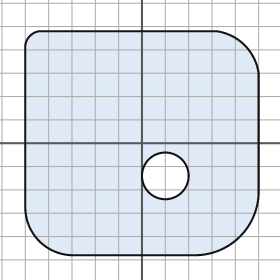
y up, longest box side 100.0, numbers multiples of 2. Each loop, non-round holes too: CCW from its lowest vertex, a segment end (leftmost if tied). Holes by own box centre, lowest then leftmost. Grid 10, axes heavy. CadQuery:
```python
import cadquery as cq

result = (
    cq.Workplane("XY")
    .moveTo(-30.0, -48.0)
    .lineTo(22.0, -48.0)
    .threePointArc((42.0, -40.0), (50.0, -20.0))
    .lineTo(50.0, 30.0)
    .threePointArc((44.0, 42.0), (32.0, 48.0))
    .lineTo(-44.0, 48.0)
    .threePointArc((-48.0, 46.0), (-50.0, 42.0))
    .lineTo(-50.0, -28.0)
    .threePointArc((-44.0, -42.0), (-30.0, -48.0))
    .close()
    .moveTo(10.0, -14.0)
    .circle(10.0)
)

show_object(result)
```